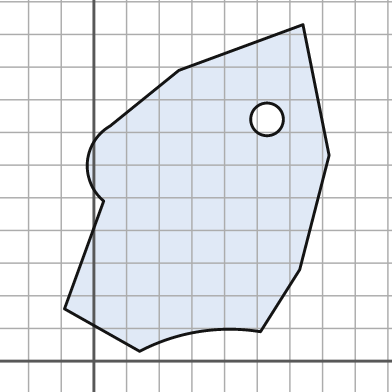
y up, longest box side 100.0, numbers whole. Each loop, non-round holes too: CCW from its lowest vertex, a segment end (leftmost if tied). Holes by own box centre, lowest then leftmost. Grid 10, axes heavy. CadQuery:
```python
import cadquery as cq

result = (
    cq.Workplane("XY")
    .moveTo(14.0, 3.0)
    .threePointArc((32.0, 9.0), (51.0, 9.0))
    .lineTo(63.0, 28.0)
    .lineTo(72.0, 63.0)
    .lineTo(64.0, 103.0)
    .lineTo(26.0, 89.0)
    .lineTo(5.0, 72.0)
    .threePointArc((-2.0, 61.0), (3.0, 49.0))
    .lineTo(-9.0, 16.0)
    .close()
    .moveTo(53.0, 74.0)
    .circle(5.0)
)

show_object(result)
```